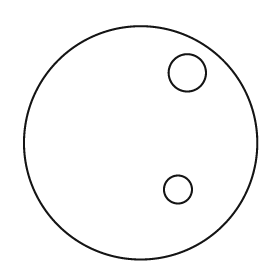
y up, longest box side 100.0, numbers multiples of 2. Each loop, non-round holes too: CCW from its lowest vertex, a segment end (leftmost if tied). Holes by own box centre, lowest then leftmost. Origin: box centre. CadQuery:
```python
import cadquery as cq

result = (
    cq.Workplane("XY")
    .moveTo(0.0, 0.0)
    .circle(50.0)
    .moveTo(16.0, -20.0)
    .circle(6.0)
    .moveTo(20.0, 30.0)
    .circle(8.0)
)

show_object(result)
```